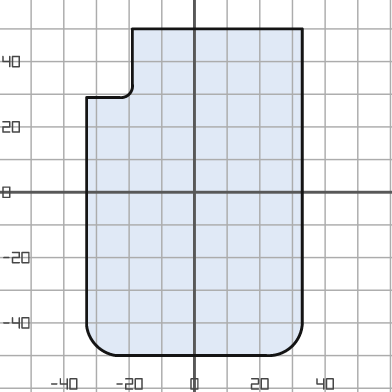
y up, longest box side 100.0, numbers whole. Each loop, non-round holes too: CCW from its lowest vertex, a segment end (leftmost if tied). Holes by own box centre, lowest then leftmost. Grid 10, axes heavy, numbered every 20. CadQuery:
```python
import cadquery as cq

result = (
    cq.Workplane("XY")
    .moveTo(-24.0, -50.0)
    .lineTo(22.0, -50.0)
    .threePointArc((30.0, -47.0), (33.0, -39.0))
    .lineTo(33.0, 50.0)
    .lineTo(-19.0, 50.0)
    .lineTo(-19.0, 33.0)
    .threePointArc((-20.0, 30.0), (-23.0, 29.0))
    .lineTo(-33.0, 29.0)
    .lineTo(-33.0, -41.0)
    .threePointArc((-30.0, -47.0), (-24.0, -50.0))
    .close()
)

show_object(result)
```